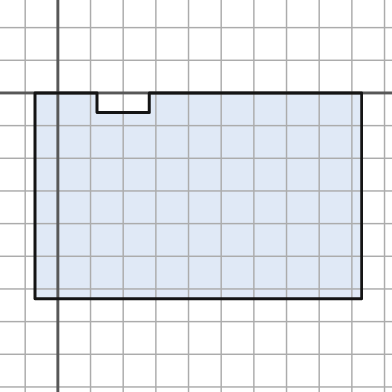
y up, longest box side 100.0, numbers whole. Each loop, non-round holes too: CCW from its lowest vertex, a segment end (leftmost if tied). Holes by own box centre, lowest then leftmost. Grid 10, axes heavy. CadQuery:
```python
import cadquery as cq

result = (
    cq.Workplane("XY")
    .moveTo(-7.0, -63.0)
    .lineTo(93.0, -63.0)
    .lineTo(93.0, 0.0)
    .lineTo(28.0, 0.0)
    .lineTo(28.0, -6.0)
    .lineTo(12.0, -6.0)
    .lineTo(12.0, 0.0)
    .lineTo(-7.0, 0.0)
    .close()
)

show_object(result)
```